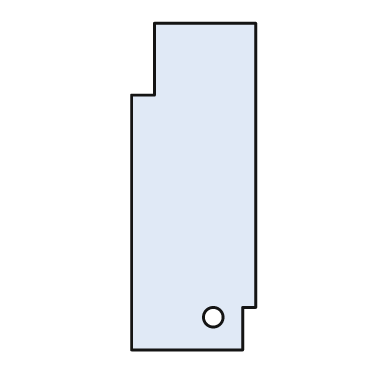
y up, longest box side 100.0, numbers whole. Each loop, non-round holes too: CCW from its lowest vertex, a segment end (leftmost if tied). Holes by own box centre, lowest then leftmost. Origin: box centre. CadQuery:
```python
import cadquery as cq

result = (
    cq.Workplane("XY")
    .moveTo(-19.0, -50.0)
    .lineTo(15.0, -50.0)
    .lineTo(15.0, -37.0)
    .lineTo(19.0, -37.0)
    .lineTo(19.0, 50.0)
    .lineTo(-12.0, 50.0)
    .lineTo(-12.0, 28.0)
    .lineTo(-19.0, 28.0)
    .close()
    .moveTo(6.0, -40.0)
    .circle(3.0)
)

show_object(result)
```